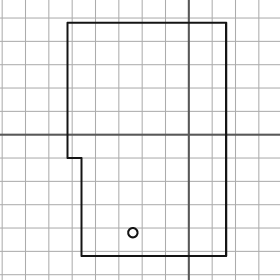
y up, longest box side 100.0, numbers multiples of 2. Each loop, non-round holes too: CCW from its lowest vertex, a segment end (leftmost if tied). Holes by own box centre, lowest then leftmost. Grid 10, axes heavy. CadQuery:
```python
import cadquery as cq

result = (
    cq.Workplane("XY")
    .moveTo(-46.0, -52.0)
    .lineTo(16.0, -52.0)
    .lineTo(16.0, 48.0)
    .lineTo(-52.0, 48.0)
    .lineTo(-52.0, -10.0)
    .lineTo(-46.0, -10.0)
    .close()
    .moveTo(-24.0, -42.0)
    .circle(2.0)
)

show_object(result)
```